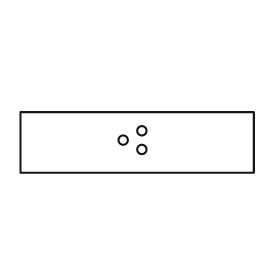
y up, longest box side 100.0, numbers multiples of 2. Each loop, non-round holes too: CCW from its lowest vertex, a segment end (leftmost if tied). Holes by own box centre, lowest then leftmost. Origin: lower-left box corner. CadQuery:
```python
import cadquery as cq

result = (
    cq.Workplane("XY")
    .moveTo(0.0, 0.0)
    .lineTo(100.0, 0.0)
    .lineTo(100.0, 26.0)
    .lineTo(0.0, 26.0)
    .close()
    .moveTo(52.0, 10.0)
    .circle(2.0)
    .moveTo(44.0, 14.0)
    .circle(2.0)
    .moveTo(52.0, 18.0)
    .circle(2.0)
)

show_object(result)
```